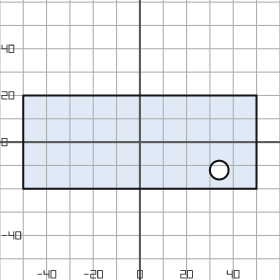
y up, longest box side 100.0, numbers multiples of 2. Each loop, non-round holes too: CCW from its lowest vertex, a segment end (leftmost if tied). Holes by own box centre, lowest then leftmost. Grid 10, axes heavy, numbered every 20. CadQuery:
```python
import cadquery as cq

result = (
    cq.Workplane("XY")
    .moveTo(-50.0, -20.0)
    .lineTo(50.0, -20.0)
    .lineTo(50.0, 20.0)
    .lineTo(-50.0, 20.0)
    .close()
    .moveTo(34.0, -12.0)
    .circle(4.0)
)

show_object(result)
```